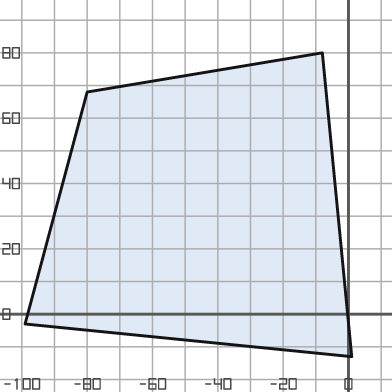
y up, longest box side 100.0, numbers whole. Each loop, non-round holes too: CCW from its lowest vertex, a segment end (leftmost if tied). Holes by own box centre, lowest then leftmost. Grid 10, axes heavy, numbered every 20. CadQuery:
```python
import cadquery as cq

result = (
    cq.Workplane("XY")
    .moveTo(1.0, -13.0)
    .lineTo(-8.0, 80.0)
    .lineTo(-80.0, 68.0)
    .lineTo(-99.0, -3.0)
    .close()
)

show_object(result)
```